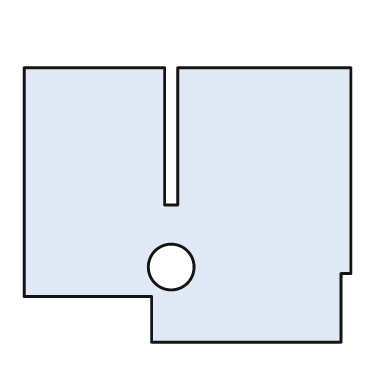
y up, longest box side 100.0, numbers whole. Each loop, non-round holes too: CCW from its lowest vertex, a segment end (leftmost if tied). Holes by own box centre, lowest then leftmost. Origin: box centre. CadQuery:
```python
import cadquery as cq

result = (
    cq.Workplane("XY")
    .moveTo(-11.0, -42.0)
    .lineTo(47.0, -42.0)
    .lineTo(47.0, -21.0)
    .lineTo(50.0, -21.0)
    .lineTo(50.0, 42.0)
    .lineTo(-3.0, 42.0)
    .lineTo(-3.0, 0.0)
    .lineTo(-7.0, 0.0)
    .lineTo(-7.0, 42.0)
    .lineTo(-50.0, 42.0)
    .lineTo(-50.0, -28.0)
    .lineTo(-11.0, -28.0)
    .close()
    .moveTo(-5.0, -19.0)
    .circle(7.0)
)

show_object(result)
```